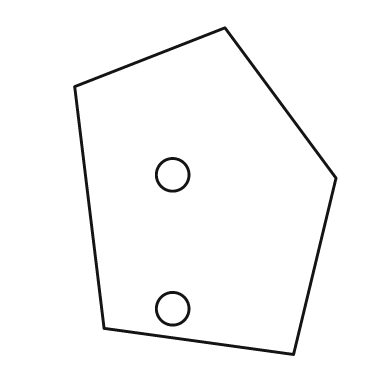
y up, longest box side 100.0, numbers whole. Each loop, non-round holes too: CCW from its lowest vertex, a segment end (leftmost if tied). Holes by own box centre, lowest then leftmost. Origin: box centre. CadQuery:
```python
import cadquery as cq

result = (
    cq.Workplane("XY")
    .moveTo(27.0, -50.0)
    .lineTo(40.0, 4.0)
    .lineTo(6.0, 50.0)
    .lineTo(-40.0, 32.0)
    .lineTo(-31.0, -42.0)
    .close()
    .moveTo(-10.0, -36.0)
    .circle(5.0)
    .moveTo(-10.0, 5.0)
    .circle(5.0)
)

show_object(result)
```